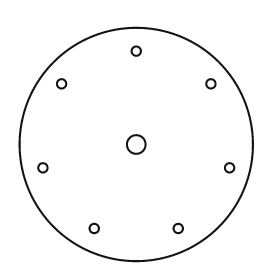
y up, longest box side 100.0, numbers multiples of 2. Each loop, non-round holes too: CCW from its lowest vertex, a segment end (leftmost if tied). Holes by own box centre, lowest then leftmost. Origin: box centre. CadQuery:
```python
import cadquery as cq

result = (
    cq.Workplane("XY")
    .moveTo(0.0, 0.0)
    .circle(50.0)
    .moveTo(-18.0, -36.0)
    .circle(2.0)
    .moveTo(18.0, -36.0)
    .circle(2.0)
    .moveTo(-40.0, -10.0)
    .circle(2.0)
    .moveTo(40.0, -10.0)
    .circle(2.0)
    .moveTo(0.0, 0.0)
    .circle(4.0)
    .moveTo(-32.0, 26.0)
    .circle(2.0)
    .moveTo(32.0, 26.0)
    .circle(2.0)
    .moveTo(0.0, 40.0)
    .circle(2.0)
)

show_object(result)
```